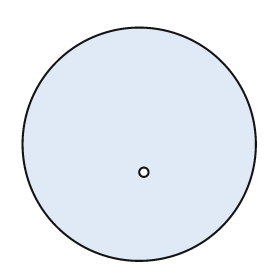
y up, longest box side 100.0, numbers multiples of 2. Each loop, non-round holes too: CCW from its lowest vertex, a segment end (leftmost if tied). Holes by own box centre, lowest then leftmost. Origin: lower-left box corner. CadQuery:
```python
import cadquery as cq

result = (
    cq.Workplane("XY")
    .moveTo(50.0, 50.0)
    .circle(50.0)
    .moveTo(52.0, 38.0)
    .circle(2.0)
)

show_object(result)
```